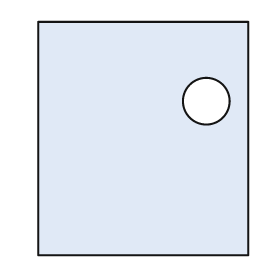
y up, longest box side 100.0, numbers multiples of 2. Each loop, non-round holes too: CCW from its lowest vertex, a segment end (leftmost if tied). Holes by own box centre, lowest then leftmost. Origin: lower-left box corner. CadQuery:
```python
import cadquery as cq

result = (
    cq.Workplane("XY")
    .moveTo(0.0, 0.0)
    .lineTo(90.0, 0.0)
    .lineTo(90.0, 100.0)
    .lineTo(0.0, 100.0)
    .close()
    .moveTo(72.0, 66.0)
    .circle(10.0)
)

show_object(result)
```